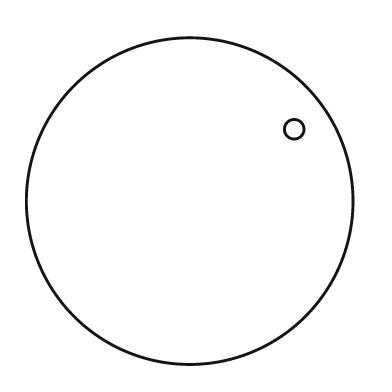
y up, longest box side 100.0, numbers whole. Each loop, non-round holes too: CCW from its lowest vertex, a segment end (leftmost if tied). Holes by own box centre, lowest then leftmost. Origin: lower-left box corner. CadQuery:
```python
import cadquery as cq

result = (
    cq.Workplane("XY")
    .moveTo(50.0, 50.0)
    .circle(50.0)
    .moveTo(82.0, 72.0)
    .circle(3.0)
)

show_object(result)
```